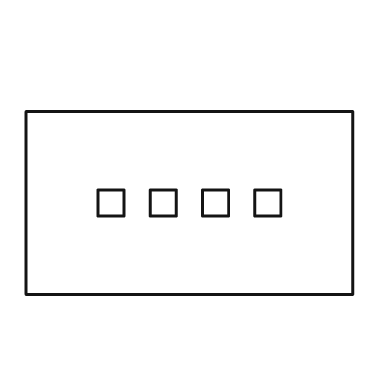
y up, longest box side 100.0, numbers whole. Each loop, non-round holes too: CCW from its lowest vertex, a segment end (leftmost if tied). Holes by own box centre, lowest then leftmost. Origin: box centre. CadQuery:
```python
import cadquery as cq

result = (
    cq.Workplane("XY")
    .moveTo(-50.0, -28.0)
    .lineTo(50.0, -28.0)
    .lineTo(50.0, 28.0)
    .lineTo(-50.0, 28.0)
    .close()
    .moveTo(-28.0, -4.0)
    .lineTo(-20.0, -4.0)
    .lineTo(-20.0, 4.0)
    .lineTo(-28.0, 4.0)
    .close()
    .moveTo(-12.0, -4.0)
    .lineTo(-4.0, -4.0)
    .lineTo(-4.0, 4.0)
    .lineTo(-12.0, 4.0)
    .close()
    .moveTo(4.0, -4.0)
    .lineTo(12.0, -4.0)
    .lineTo(12.0, 4.0)
    .lineTo(4.0, 4.0)
    .close()
    .moveTo(20.0, -4.0)
    .lineTo(28.0, -4.0)
    .lineTo(28.0, 4.0)
    .lineTo(20.0, 4.0)
    .close()
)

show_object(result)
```